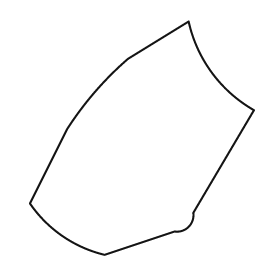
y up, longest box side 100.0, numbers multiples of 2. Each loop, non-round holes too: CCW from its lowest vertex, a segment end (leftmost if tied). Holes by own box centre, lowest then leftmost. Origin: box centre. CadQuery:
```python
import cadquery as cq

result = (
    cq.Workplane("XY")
    .moveTo(-16.0, -50.0)
    .lineTo(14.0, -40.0)
    .threePointArc((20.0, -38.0), (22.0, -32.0))
    .lineTo(48.0, 12.0)
    .threePointArc((30.0, 28.0), (20.0, 50.0))
    .lineTo(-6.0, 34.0)
    .threePointArc((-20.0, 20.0), (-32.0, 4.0))
    .lineTo(-48.0, -28.0)
    .threePointArc((-34.0, -42.0), (-16.0, -50.0))
    .close()
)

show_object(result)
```